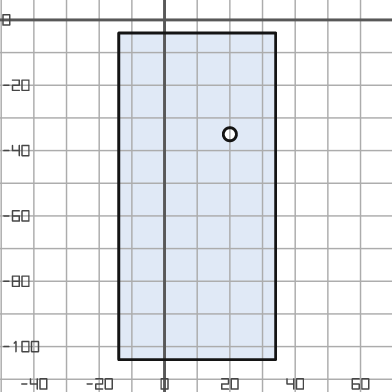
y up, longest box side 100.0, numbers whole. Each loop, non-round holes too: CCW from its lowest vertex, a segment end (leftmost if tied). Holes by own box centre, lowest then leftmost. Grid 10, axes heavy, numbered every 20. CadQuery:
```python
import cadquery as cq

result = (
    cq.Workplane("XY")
    .moveTo(-14.0, -104.0)
    .lineTo(34.0, -104.0)
    .lineTo(34.0, -4.0)
    .lineTo(-14.0, -4.0)
    .close()
    .moveTo(20.0, -35.0)
    .circle(2.0)
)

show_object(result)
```